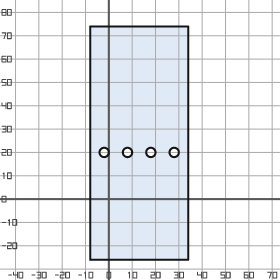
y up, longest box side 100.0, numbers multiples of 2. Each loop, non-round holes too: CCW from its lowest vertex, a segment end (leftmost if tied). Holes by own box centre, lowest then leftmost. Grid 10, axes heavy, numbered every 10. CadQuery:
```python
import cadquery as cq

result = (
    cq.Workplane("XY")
    .moveTo(-8.0, -26.0)
    .lineTo(34.0, -26.0)
    .lineTo(34.0, 74.0)
    .lineTo(-8.0, 74.0)
    .close()
    .moveTo(-2.0, 20.0)
    .circle(2.0)
    .moveTo(8.0, 20.0)
    .circle(2.0)
    .moveTo(18.0, 20.0)
    .circle(2.0)
    .moveTo(28.0, 20.0)
    .circle(2.0)
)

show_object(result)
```